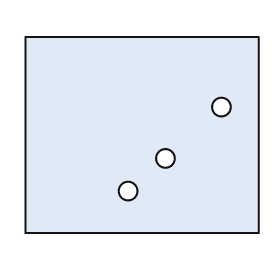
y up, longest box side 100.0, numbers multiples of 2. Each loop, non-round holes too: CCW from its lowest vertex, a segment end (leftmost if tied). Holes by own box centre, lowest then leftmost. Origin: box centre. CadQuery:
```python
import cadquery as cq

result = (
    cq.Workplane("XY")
    .moveTo(-50.0, -42.0)
    .lineTo(50.0, -42.0)
    .lineTo(50.0, 42.0)
    .lineTo(-50.0, 42.0)
    .close()
    .moveTo(-6.0, -24.0)
    .circle(4.0)
    .moveTo(10.0, -10.0)
    .circle(4.0)
    .moveTo(34.0, 12.0)
    .circle(4.0)
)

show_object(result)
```